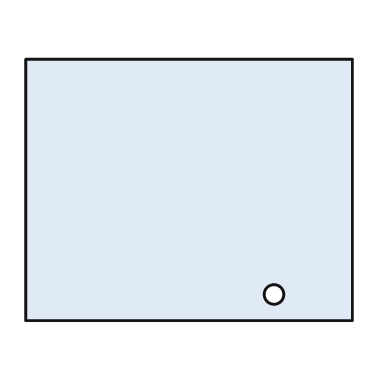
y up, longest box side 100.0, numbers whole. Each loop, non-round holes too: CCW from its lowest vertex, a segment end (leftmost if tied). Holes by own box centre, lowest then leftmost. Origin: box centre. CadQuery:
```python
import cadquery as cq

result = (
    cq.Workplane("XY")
    .moveTo(-50.0, -40.0)
    .lineTo(50.0, -40.0)
    .lineTo(50.0, 40.0)
    .lineTo(-50.0, 40.0)
    .close()
    .moveTo(26.0, -32.0)
    .circle(3.0)
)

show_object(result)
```